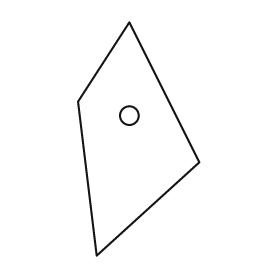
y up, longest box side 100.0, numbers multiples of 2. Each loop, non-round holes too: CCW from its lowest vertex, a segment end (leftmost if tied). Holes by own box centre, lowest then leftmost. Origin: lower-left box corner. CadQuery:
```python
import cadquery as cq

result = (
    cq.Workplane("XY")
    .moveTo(8.0, 0.0)
    .lineTo(52.0, 40.0)
    .lineTo(22.0, 100.0)
    .lineTo(0.0, 66.0)
    .close()
    .moveTo(22.0, 60.0)
    .circle(4.0)
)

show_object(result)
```